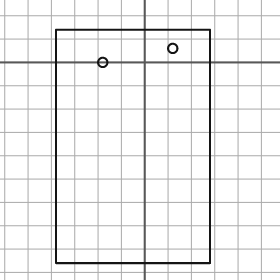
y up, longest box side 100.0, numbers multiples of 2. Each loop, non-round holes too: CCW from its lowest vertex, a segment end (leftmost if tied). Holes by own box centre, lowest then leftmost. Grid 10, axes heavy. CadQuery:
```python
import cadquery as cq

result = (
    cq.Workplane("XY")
    .moveTo(-38.0, -86.0)
    .lineTo(28.0, -86.0)
    .lineTo(28.0, 14.0)
    .lineTo(-38.0, 14.0)
    .close()
    .moveTo(-18.0, 0.0)
    .circle(2.0)
    .moveTo(12.0, 6.0)
    .circle(2.0)
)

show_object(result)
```